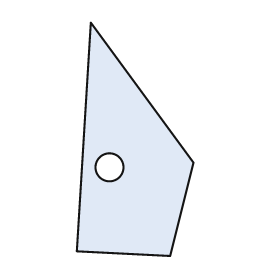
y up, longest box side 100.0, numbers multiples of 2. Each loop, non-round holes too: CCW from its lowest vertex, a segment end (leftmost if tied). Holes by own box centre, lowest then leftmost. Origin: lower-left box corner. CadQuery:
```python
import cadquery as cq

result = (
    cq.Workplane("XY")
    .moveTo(40.0, 0.0)
    .lineTo(50.0, 40.0)
    .lineTo(6.0, 100.0)
    .lineTo(0.0, 2.0)
    .close()
    .moveTo(14.0, 38.0)
    .circle(6.0)
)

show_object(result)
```